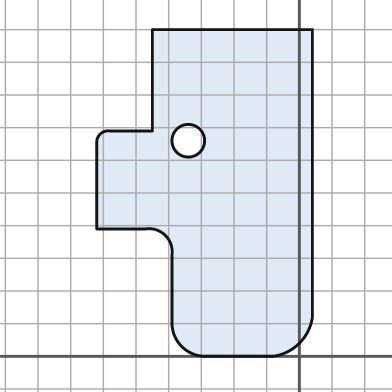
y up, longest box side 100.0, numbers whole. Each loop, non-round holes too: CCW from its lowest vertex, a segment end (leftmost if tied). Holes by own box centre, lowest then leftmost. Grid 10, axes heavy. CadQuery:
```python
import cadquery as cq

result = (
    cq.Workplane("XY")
    .moveTo(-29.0, 0.0)
    .lineTo(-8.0, 0.0)
    .threePointArc((0.0, 4.0), (4.0, 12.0))
    .lineTo(4.0, 100.0)
    .lineTo(-45.0, 100.0)
    .lineTo(-45.0, 69.0)
    .lineTo(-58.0, 69.0)
    .threePointArc((-61.0, 68.0), (-62.0, 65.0))
    .lineTo(-62.0, 39.0)
    .lineTo(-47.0, 39.0)
    .threePointArc((-41.0, 37.0), (-39.0, 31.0))
    .lineTo(-39.0, 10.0)
    .threePointArc((-36.0, 3.0), (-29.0, 0.0))
    .close()
    .moveTo(-34.0, 66.0)
    .circle(5.0)
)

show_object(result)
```